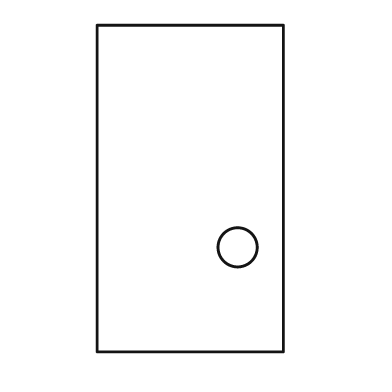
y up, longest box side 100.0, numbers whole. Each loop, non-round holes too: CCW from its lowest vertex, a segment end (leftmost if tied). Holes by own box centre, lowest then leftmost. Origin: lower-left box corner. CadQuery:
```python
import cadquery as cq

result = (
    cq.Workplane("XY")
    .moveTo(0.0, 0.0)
    .lineTo(57.0, 0.0)
    .lineTo(57.0, 100.0)
    .lineTo(0.0, 100.0)
    .close()
    .moveTo(43.0, 32.0)
    .circle(6.0)
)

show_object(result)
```